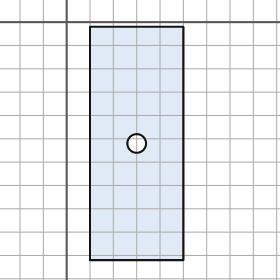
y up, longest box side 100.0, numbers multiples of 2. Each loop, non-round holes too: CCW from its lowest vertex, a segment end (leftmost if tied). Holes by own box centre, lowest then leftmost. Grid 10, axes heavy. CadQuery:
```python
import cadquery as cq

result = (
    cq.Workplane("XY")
    .moveTo(10.0, -102.0)
    .lineTo(50.0, -102.0)
    .lineTo(50.0, -2.0)
    .lineTo(10.0, -2.0)
    .close()
    .moveTo(30.0, -52.0)
    .circle(4.0)
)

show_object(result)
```